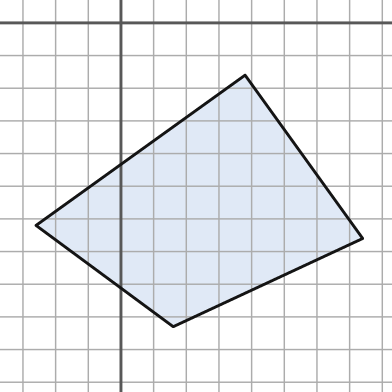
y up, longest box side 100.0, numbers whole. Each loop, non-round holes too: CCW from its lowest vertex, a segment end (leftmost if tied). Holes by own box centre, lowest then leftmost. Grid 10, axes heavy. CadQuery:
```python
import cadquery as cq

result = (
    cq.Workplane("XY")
    .moveTo(16.0, -93.0)
    .lineTo(74.0, -66.0)
    .lineTo(38.0, -16.0)
    .lineTo(-26.0, -62.0)
    .close()
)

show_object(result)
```